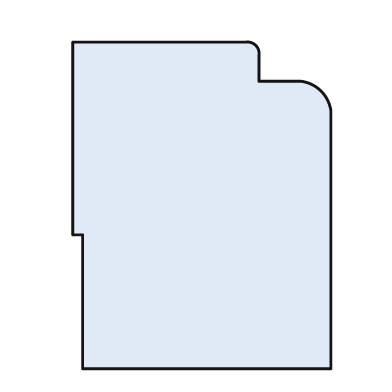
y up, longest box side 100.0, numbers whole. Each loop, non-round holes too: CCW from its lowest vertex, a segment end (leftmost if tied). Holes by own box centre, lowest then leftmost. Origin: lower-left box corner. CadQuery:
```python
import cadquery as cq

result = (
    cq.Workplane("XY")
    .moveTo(3.0, 0.0)
    .lineTo(79.0, 0.0)
    .lineTo(79.0, 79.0)
    .threePointArc((76.0, 85.0), (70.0, 88.0))
    .lineTo(57.0, 88.0)
    .lineTo(57.0, 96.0)
    .threePointArc((56.0, 99.0), (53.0, 100.0))
    .lineTo(0.0, 100.0)
    .lineTo(0.0, 41.0)
    .lineTo(3.0, 41.0)
    .close()
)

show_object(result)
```